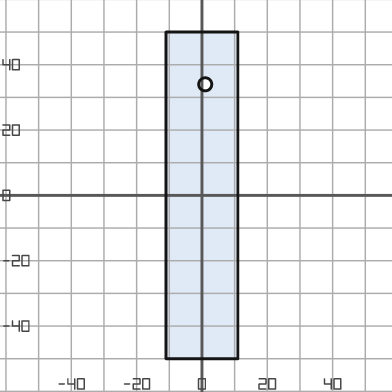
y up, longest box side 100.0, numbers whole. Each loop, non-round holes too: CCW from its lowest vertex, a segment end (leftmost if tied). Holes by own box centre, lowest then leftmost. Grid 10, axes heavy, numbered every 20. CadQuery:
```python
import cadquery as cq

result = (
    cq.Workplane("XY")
    .moveTo(-11.0, -50.0)
    .lineTo(11.0, -50.0)
    .lineTo(11.0, 50.0)
    .lineTo(-11.0, 50.0)
    .close()
    .moveTo(1.0, 34.0)
    .circle(2.0)
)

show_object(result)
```